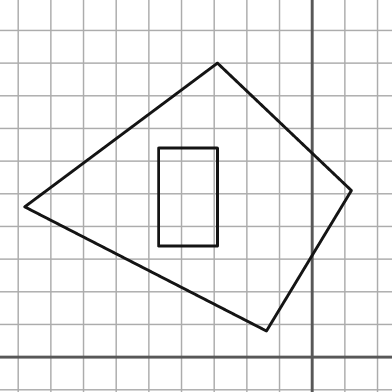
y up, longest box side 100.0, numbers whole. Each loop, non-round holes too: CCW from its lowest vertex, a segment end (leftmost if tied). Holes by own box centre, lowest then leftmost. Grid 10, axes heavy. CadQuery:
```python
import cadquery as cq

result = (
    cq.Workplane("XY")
    .moveTo(-14.0, 8.0)
    .lineTo(12.0, 51.0)
    .lineTo(-29.0, 90.0)
    .lineTo(-88.0, 46.0)
    .close()
    .moveTo(-47.0, 34.0)
    .lineTo(-29.0, 34.0)
    .lineTo(-29.0, 64.0)
    .lineTo(-47.0, 64.0)
    .close()
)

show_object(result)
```